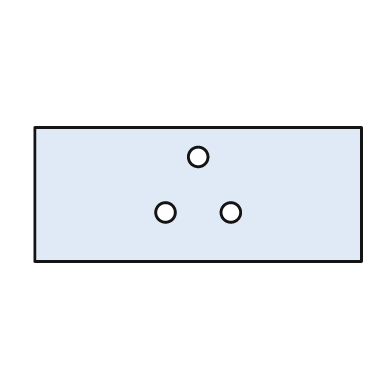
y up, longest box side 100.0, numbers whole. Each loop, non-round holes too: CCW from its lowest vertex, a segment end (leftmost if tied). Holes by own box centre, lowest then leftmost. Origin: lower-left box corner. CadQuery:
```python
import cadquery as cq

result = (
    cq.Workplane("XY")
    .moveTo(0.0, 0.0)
    .lineTo(100.0, 0.0)
    .lineTo(100.0, 41.0)
    .lineTo(0.0, 41.0)
    .close()
    .moveTo(40.0, 15.0)
    .circle(3.0)
    .moveTo(60.0, 15.0)
    .circle(3.0)
    .moveTo(50.0, 32.0)
    .circle(3.0)
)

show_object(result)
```